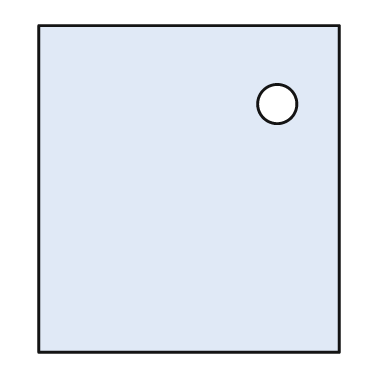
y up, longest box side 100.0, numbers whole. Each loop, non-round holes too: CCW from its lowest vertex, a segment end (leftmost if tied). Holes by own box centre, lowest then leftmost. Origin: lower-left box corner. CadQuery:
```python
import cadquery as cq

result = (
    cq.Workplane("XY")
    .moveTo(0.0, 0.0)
    .lineTo(92.0, 0.0)
    .lineTo(92.0, 100.0)
    .lineTo(0.0, 100.0)
    .close()
    .moveTo(73.0, 76.0)
    .circle(6.0)
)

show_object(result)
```